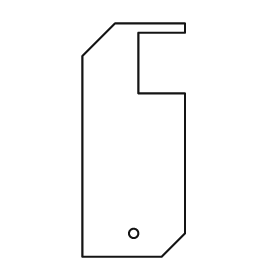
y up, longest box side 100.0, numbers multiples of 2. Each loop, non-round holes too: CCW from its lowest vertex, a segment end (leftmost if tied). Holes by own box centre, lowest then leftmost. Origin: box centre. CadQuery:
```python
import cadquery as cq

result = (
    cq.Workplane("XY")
    .moveTo(-22.0, -50.0)
    .lineTo(12.0, -50.0)
    .lineTo(22.0, -40.0)
    .lineTo(22.0, 20.0)
    .lineTo(2.0, 20.0)
    .lineTo(2.0, 46.0)
    .lineTo(22.0, 46.0)
    .lineTo(22.0, 50.0)
    .lineTo(-8.0, 50.0)
    .lineTo(-22.0, 36.0)
    .close()
    .moveTo(0.0, -40.0)
    .circle(2.0)
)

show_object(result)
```